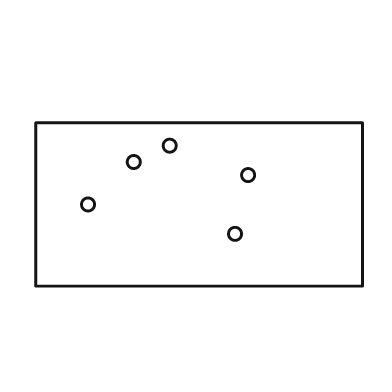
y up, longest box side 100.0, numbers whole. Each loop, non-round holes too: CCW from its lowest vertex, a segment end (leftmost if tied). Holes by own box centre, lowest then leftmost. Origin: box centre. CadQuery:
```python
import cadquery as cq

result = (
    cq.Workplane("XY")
    .moveTo(-50.0, -25.0)
    .lineTo(50.0, -25.0)
    .lineTo(50.0, 25.0)
    .lineTo(-50.0, 25.0)
    .close()
    .moveTo(11.0, -9.0)
    .circle(2.0)
    .moveTo(-34.0, 0.0)
    .circle(2.0)
    .moveTo(15.0, 9.0)
    .circle(2.0)
    .moveTo(-20.0, 13.0)
    .circle(2.0)
    .moveTo(-9.0, 18.0)
    .circle(2.0)
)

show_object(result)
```